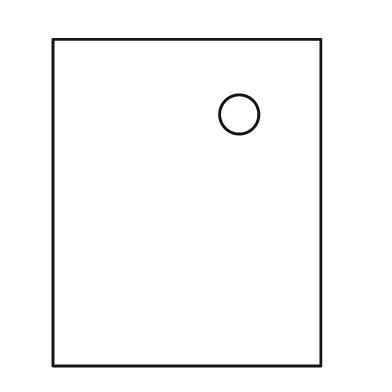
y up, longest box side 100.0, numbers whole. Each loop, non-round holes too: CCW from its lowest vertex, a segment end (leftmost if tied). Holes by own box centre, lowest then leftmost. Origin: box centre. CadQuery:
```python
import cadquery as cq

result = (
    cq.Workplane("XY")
    .moveTo(-41.0, -50.0)
    .lineTo(41.0, -50.0)
    .lineTo(41.0, 50.0)
    .lineTo(-41.0, 50.0)
    .close()
    .moveTo(16.0, 27.0)
    .circle(6.0)
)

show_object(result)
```